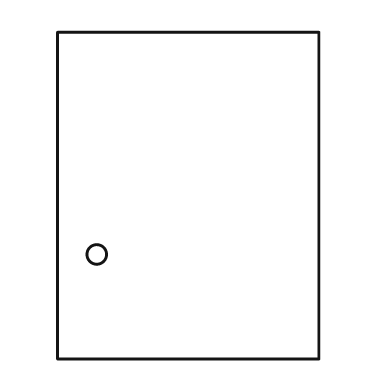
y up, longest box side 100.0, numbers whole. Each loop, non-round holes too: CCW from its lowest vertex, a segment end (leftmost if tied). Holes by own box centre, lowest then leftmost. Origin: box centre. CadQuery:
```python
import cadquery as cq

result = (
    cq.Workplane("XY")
    .moveTo(-40.0, -50.0)
    .lineTo(40.0, -50.0)
    .lineTo(40.0, 50.0)
    .lineTo(-40.0, 50.0)
    .close()
    .moveTo(-28.0, -18.0)
    .circle(3.0)
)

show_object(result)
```